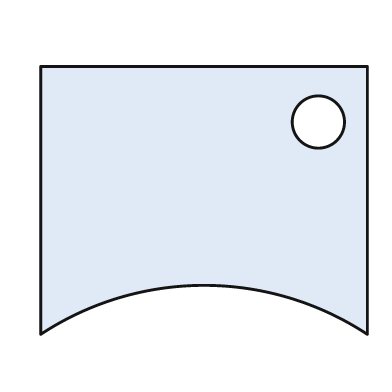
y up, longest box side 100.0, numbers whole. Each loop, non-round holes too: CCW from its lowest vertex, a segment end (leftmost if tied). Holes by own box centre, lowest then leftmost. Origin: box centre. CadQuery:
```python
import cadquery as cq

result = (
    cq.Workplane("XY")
    .moveTo(-50.0, -41.0)
    .threePointArc((0.0, -26.0), (50.0, -41.0))
    .lineTo(50.0, 41.0)
    .lineTo(-50.0, 41.0)
    .close()
    .moveTo(35.0, 24.0)
    .circle(8.0)
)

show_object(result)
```